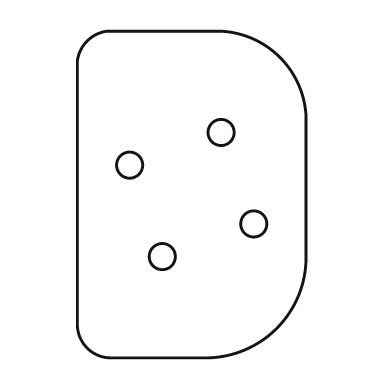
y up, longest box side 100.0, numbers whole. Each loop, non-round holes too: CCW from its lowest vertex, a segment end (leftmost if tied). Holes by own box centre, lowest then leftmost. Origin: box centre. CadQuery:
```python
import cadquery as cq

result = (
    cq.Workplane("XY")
    .moveTo(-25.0, -50.0)
    .lineTo(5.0, -50.0)
    .threePointArc((26.0, -41.0), (35.0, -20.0))
    .lineTo(35.0, 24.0)
    .threePointArc((27.0, 42.0), (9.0, 50.0))
    .lineTo(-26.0, 50.0)
    .threePointArc((-32.0, 47.0), (-35.0, 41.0))
    .lineTo(-35.0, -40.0)
    .threePointArc((-32.0, -47.0), (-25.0, -50.0))
    .close()
    .moveTo(-9.0, -19.0)
    .circle(4.0)
    .moveTo(19.0, -9.0)
    .circle(4.0)
    .moveTo(-19.0, 9.0)
    .circle(4.0)
    .moveTo(9.0, 19.0)
    .circle(4.0)
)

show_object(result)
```